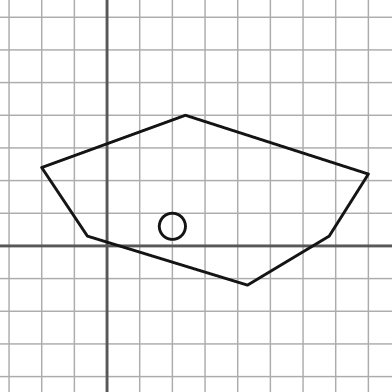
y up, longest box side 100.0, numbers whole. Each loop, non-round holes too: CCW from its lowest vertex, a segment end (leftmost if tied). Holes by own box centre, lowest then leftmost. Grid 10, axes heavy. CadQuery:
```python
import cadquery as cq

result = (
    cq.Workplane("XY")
    .moveTo(43.0, -12.0)
    .lineTo(68.0, 3.0)
    .lineTo(80.0, 22.0)
    .lineTo(24.0, 40.0)
    .lineTo(-20.0, 24.0)
    .lineTo(-6.0, 3.0)
    .close()
    .moveTo(20.0, 6.0)
    .circle(4.0)
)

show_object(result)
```